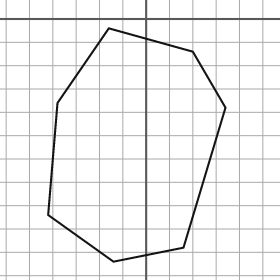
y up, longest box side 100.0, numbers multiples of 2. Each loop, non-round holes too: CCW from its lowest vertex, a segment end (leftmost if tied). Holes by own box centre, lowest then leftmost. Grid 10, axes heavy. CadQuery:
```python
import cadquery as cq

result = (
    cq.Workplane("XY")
    .moveTo(-14.0, -104.0)
    .lineTo(16.0, -98.0)
    .lineTo(34.0, -38.0)
    .lineTo(20.0, -14.0)
    .lineTo(-16.0, -4.0)
    .lineTo(-38.0, -36.0)
    .lineTo(-42.0, -84.0)
    .close()
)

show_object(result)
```